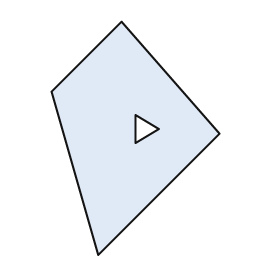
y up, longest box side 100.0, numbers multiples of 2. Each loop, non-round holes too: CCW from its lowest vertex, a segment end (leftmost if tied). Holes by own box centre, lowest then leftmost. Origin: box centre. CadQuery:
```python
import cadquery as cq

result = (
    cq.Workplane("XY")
    .moveTo(-16.0, -50.0)
    .lineTo(36.0, 2.0)
    .lineTo(-6.0, 50.0)
    .lineTo(-36.0, 20.0)
    .close()
    .moveTo(0.0, -2.0)
    .lineTo(10.0, 4.0)
    .lineTo(0.0, 10.0)
    .close()
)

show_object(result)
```